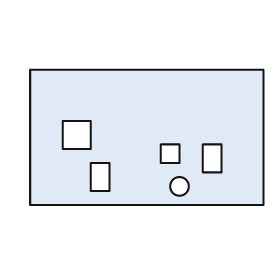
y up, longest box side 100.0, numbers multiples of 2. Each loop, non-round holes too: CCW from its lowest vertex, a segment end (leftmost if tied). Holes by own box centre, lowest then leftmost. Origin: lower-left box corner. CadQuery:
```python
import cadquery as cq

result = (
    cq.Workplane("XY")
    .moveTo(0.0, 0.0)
    .lineTo(100.0, 0.0)
    .lineTo(100.0, 58.0)
    .lineTo(0.0, 58.0)
    .close()
    .moveTo(64.0, 8.0)
    .circle(4.0)
    .moveTo(26.0, 6.0)
    .lineTo(34.0, 6.0)
    .lineTo(34.0, 18.0)
    .lineTo(26.0, 18.0)
    .close()
    .moveTo(74.0, 14.0)
    .lineTo(82.0, 14.0)
    .lineTo(82.0, 26.0)
    .lineTo(74.0, 26.0)
    .close()
    .moveTo(56.0, 18.0)
    .lineTo(64.0, 18.0)
    .lineTo(64.0, 26.0)
    .lineTo(56.0, 26.0)
    .close()
    .moveTo(14.0, 24.0)
    .lineTo(26.0, 24.0)
    .lineTo(26.0, 36.0)
    .lineTo(14.0, 36.0)
    .close()
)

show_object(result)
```